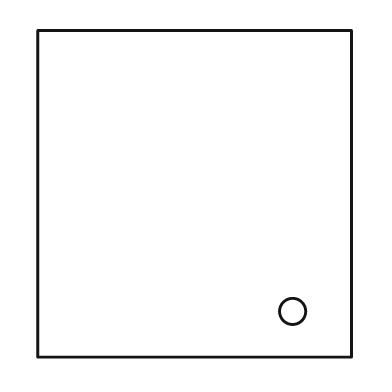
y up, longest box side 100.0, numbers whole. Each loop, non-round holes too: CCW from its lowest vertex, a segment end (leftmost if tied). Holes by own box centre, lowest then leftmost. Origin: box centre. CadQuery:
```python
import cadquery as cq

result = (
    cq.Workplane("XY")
    .moveTo(-48.0, -50.0)
    .lineTo(48.0, -50.0)
    .lineTo(48.0, 50.0)
    .lineTo(-48.0, 50.0)
    .close()
    .moveTo(30.0, -36.0)
    .circle(4.0)
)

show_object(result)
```